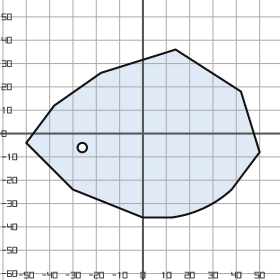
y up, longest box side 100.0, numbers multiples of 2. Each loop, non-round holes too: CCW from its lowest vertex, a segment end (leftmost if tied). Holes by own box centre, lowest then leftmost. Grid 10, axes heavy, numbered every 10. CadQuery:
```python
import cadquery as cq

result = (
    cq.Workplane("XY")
    .moveTo(0.0, -36.0)
    .lineTo(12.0, -36.0)
    .threePointArc((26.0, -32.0), (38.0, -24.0))
    .lineTo(50.0, -8.0)
    .lineTo(42.0, 18.0)
    .lineTo(14.0, 36.0)
    .lineTo(-18.0, 26.0)
    .lineTo(-38.0, 12.0)
    .lineTo(-50.0, -4.0)
    .lineTo(-30.0, -24.0)
    .close()
    .moveTo(-26.0, -6.0)
    .circle(2.0)
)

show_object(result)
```